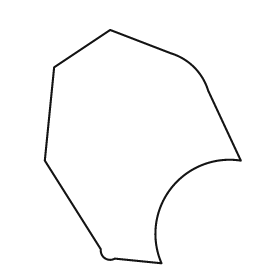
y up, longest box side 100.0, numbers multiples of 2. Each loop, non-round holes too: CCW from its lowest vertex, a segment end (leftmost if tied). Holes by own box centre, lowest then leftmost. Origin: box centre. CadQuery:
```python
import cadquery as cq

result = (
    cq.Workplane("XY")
    .moveTo(8.0, -50.0)
    .threePointArc((12.0, -18.0), (42.0, -6.0))
    .lineTo(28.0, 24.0)
    .threePointArc((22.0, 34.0), (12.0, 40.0))
    .lineTo(-14.0, 50.0)
    .lineTo(-38.0, 34.0)
    .lineTo(-42.0, -6.0)
    .lineTo(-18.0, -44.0)
    .threePointArc((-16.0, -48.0), (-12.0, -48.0))
    .close()
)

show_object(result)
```